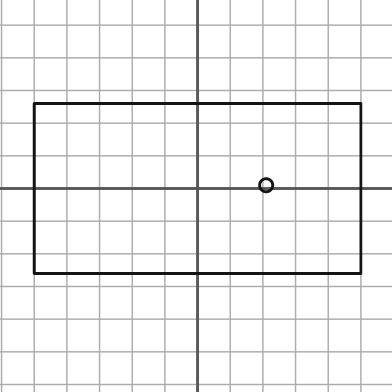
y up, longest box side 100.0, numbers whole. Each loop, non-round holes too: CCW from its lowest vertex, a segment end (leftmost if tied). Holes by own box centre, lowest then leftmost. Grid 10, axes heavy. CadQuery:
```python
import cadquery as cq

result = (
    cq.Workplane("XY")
    .moveTo(-50.0, -26.0)
    .lineTo(50.0, -26.0)
    .lineTo(50.0, 26.0)
    .lineTo(-50.0, 26.0)
    .close()
    .moveTo(21.0, 1.0)
    .circle(2.0)
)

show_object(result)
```